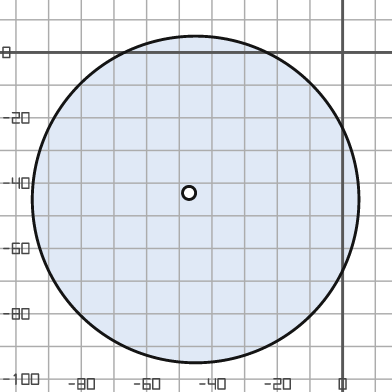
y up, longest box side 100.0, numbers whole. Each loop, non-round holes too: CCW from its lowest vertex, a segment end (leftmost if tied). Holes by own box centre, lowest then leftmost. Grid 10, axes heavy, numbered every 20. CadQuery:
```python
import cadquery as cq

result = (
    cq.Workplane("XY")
    .moveTo(-45.0, -45.0)
    .circle(50.0)
    .moveTo(-47.0, -43.0)
    .circle(2.0)
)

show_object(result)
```